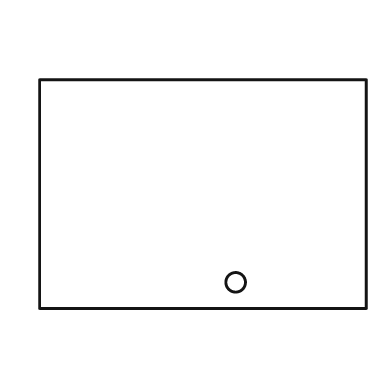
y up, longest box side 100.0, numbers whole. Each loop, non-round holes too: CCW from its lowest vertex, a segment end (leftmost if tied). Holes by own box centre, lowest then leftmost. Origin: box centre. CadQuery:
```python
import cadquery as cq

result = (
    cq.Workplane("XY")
    .moveTo(-50.0, -35.0)
    .lineTo(50.0, -35.0)
    .lineTo(50.0, 35.0)
    .lineTo(-50.0, 35.0)
    .close()
    .moveTo(10.0, -27.0)
    .circle(3.0)
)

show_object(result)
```